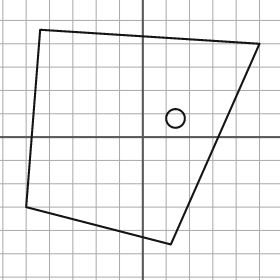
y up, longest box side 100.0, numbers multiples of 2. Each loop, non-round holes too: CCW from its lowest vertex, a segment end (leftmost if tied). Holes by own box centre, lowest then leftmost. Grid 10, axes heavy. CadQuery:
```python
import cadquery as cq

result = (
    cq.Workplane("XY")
    .moveTo(12.0, -46.0)
    .lineTo(50.0, 40.0)
    .lineTo(-44.0, 46.0)
    .lineTo(-50.0, -30.0)
    .close()
    .moveTo(14.0, 8.0)
    .circle(4.0)
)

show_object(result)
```